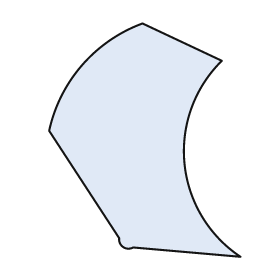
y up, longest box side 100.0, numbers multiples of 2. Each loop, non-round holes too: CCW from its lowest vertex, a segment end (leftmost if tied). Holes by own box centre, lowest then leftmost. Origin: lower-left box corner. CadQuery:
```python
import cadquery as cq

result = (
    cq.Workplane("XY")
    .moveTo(82.0, 0.0)
    .threePointArc((58.0, 40.0), (74.0, 84.0))
    .lineTo(40.0, 100.0)
    .threePointArc((14.0, 82.0), (0.0, 54.0))
    .lineTo(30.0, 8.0)
    .threePointArc((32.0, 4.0), (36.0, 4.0))
    .close()
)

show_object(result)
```